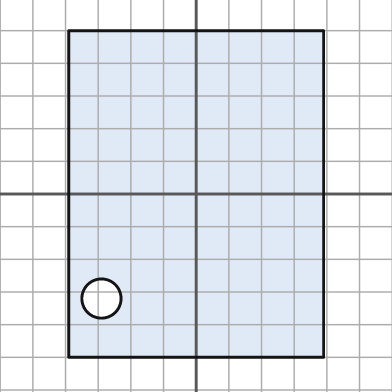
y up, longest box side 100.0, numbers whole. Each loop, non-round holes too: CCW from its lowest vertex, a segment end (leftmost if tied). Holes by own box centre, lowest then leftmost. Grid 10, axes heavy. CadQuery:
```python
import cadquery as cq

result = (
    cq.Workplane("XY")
    .moveTo(-39.0, -50.0)
    .lineTo(39.0, -50.0)
    .lineTo(39.0, 50.0)
    .lineTo(-39.0, 50.0)
    .close()
    .moveTo(-29.0, -32.0)
    .circle(6.0)
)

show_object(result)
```